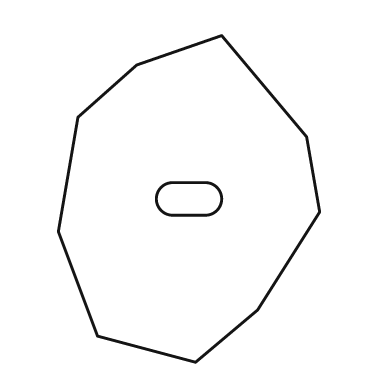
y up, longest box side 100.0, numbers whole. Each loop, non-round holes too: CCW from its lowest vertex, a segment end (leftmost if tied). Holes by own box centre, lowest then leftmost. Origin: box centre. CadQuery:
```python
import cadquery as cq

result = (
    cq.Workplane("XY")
    .moveTo(2.0, -50.0)
    .lineTo(21.0, -34.0)
    .lineTo(40.0, -4.0)
    .lineTo(36.0, 19.0)
    .lineTo(10.0, 50.0)
    .lineTo(-16.0, 41.0)
    .lineTo(-34.0, 25.0)
    .lineTo(-40.0, -10.0)
    .lineTo(-28.0, -42.0)
    .close()
    .moveTo(-5.0, -5.0)
    .lineTo(5.0, -5.0)
    .threePointArc((10.0, 0.0), (5.0, 5.0))
    .lineTo(-5.0, 5.0)
    .threePointArc((-10.0, 0.0), (-5.0, -5.0))
    .close()
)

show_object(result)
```